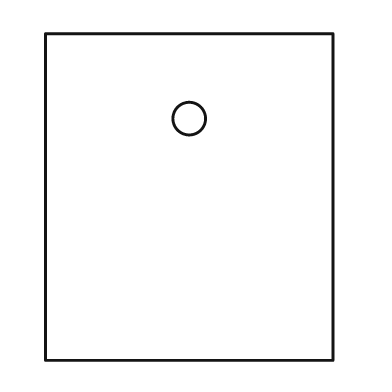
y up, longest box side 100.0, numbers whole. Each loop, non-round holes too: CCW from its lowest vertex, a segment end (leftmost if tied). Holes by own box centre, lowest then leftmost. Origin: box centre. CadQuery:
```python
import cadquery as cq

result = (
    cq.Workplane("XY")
    .moveTo(-44.0, -50.0)
    .lineTo(44.0, -50.0)
    .lineTo(44.0, 50.0)
    .lineTo(-44.0, 50.0)
    .close()
    .moveTo(0.0, 24.0)
    .circle(5.0)
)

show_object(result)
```